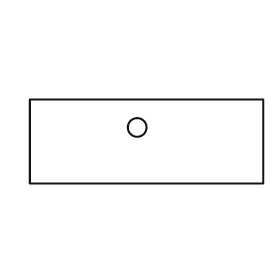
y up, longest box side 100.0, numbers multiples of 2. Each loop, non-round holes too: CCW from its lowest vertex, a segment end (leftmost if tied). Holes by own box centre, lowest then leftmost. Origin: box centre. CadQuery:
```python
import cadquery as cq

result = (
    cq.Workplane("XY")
    .moveTo(-50.0, -18.0)
    .lineTo(50.0, -18.0)
    .lineTo(50.0, 18.0)
    .lineTo(-50.0, 18.0)
    .close()
    .moveTo(-4.0, 6.0)
    .circle(4.0)
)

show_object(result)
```